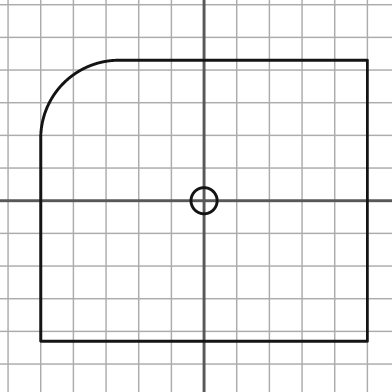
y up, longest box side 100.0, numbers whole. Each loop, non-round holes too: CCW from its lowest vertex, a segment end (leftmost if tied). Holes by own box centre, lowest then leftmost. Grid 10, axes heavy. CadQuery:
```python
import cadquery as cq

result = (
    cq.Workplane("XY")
    .moveTo(-50.0, -43.0)
    .lineTo(50.0, -43.0)
    .lineTo(50.0, 43.0)
    .lineTo(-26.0, 43.0)
    .threePointArc((-43.0, 36.0), (-50.0, 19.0))
    .close()
    .moveTo(0.0, 0.0)
    .circle(4.0)
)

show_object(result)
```